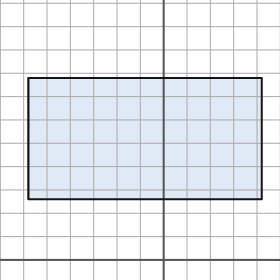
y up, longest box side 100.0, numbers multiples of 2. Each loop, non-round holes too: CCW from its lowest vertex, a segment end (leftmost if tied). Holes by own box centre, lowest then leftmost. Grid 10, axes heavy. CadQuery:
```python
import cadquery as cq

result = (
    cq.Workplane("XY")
    .moveTo(-58.0, 26.0)
    .lineTo(42.0, 26.0)
    .lineTo(42.0, 78.0)
    .lineTo(-58.0, 78.0)
    .close()
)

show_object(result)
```